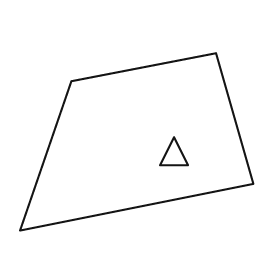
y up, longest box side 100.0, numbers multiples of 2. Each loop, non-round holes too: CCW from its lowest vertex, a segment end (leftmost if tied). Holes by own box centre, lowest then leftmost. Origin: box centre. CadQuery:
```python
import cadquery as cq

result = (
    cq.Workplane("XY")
    .moveTo(-50.0, -38.0)
    .lineTo(50.0, -18.0)
    .lineTo(34.0, 38.0)
    .lineTo(-28.0, 26.0)
    .close()
    .moveTo(10.0, -10.0)
    .lineTo(22.0, -10.0)
    .lineTo(16.0, 2.0)
    .close()
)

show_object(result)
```